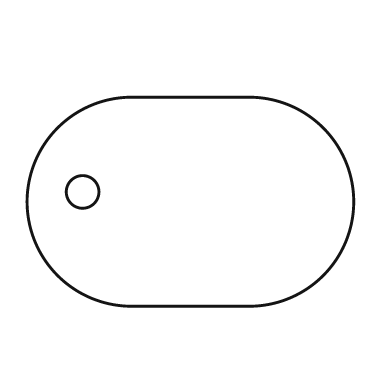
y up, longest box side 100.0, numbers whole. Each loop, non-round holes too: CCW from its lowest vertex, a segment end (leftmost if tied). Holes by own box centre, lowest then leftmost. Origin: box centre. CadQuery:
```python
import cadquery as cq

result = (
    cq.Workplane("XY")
    .moveTo(-18.0, -32.0)
    .lineTo(18.0, -32.0)
    .threePointArc((50.0, 0.0), (18.0, 32.0))
    .lineTo(-18.0, 32.0)
    .threePointArc((-50.0, 0.0), (-18.0, -32.0))
    .close()
    .moveTo(-33.0, 3.0)
    .circle(5.0)
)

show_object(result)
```